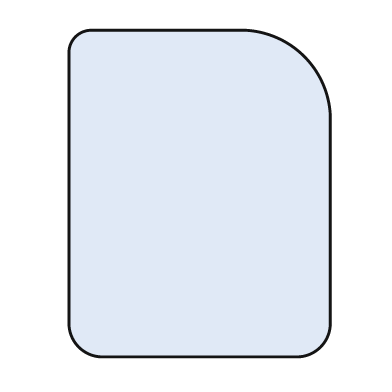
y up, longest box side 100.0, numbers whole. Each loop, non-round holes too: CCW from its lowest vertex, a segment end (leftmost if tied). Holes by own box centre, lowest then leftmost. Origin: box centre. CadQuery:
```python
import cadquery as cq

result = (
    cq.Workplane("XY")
    .moveTo(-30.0, -50.0)
    .lineTo(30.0, -50.0)
    .threePointArc((37.0, -47.0), (40.0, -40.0))
    .lineTo(40.0, 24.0)
    .threePointArc((32.0, 42.0), (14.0, 50.0))
    .lineTo(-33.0, 50.0)
    .threePointArc((-38.0, 48.0), (-40.0, 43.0))
    .lineTo(-40.0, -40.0)
    .threePointArc((-37.0, -47.0), (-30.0, -50.0))
    .close()
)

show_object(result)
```